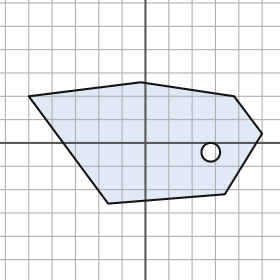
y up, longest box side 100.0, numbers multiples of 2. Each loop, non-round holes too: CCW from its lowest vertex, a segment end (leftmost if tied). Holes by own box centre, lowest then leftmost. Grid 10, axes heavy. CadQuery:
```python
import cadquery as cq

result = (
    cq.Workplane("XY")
    .moveTo(-16.0, -26.0)
    .lineTo(34.0, -22.0)
    .lineTo(50.0, 4.0)
    .lineTo(38.0, 20.0)
    .lineTo(-2.0, 26.0)
    .lineTo(-50.0, 20.0)
    .close()
    .moveTo(28.0, -4.0)
    .circle(4.0)
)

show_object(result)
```